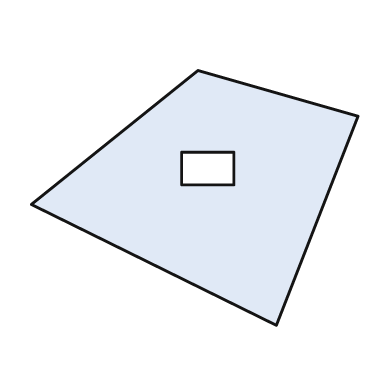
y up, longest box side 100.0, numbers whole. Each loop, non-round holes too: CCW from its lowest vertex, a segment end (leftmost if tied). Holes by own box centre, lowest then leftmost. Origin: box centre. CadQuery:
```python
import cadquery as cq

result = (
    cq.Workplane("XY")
    .moveTo(25.0, -39.0)
    .lineTo(50.0, 25.0)
    .lineTo(1.0, 39.0)
    .lineTo(-50.0, -2.0)
    .close()
    .moveTo(-4.0, 4.0)
    .lineTo(12.0, 4.0)
    .lineTo(12.0, 14.0)
    .lineTo(-4.0, 14.0)
    .close()
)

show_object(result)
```